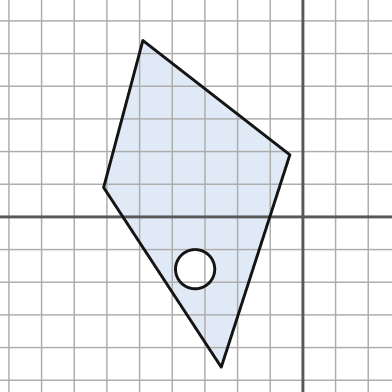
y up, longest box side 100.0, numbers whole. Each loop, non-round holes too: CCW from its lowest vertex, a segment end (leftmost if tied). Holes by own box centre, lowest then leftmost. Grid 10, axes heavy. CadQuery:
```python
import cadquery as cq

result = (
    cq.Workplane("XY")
    .moveTo(-25.0, -46.0)
    .lineTo(-4.0, 19.0)
    .lineTo(-49.0, 54.0)
    .lineTo(-61.0, 9.0)
    .close()
    .moveTo(-33.0, -16.0)
    .circle(6.0)
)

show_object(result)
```